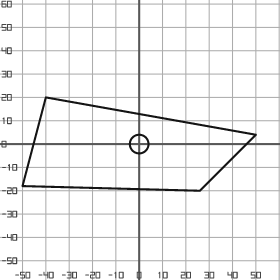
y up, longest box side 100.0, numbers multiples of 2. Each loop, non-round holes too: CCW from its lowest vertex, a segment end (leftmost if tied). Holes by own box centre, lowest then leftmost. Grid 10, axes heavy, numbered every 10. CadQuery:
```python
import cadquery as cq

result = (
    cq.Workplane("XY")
    .moveTo(26.0, -20.0)
    .lineTo(50.0, 4.0)
    .lineTo(-40.0, 20.0)
    .lineTo(-50.0, -18.0)
    .close()
    .moveTo(0.0, 0.0)
    .circle(4.0)
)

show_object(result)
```